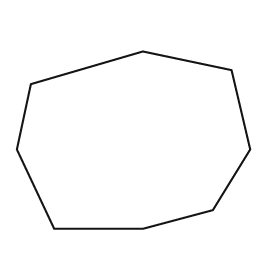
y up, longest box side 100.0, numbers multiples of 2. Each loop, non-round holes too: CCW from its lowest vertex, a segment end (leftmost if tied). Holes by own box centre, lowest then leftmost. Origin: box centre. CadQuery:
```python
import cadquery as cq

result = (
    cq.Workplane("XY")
    .moveTo(-34.0, -38.0)
    .lineTo(4.0, -38.0)
    .lineTo(34.0, -30.0)
    .lineTo(50.0, -4.0)
    .lineTo(42.0, 30.0)
    .lineTo(4.0, 38.0)
    .lineTo(-44.0, 24.0)
    .lineTo(-50.0, -4.0)
    .close()
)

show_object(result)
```